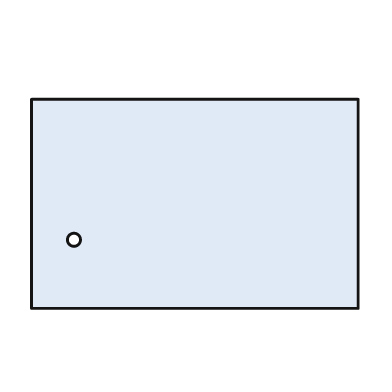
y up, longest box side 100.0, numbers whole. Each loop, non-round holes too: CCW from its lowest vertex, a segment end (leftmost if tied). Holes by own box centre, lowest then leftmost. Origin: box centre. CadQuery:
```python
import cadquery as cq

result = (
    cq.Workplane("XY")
    .moveTo(-50.0, -32.0)
    .lineTo(50.0, -32.0)
    .lineTo(50.0, 32.0)
    .lineTo(-50.0, 32.0)
    .close()
    .moveTo(-37.0, -11.0)
    .circle(2.0)
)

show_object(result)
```